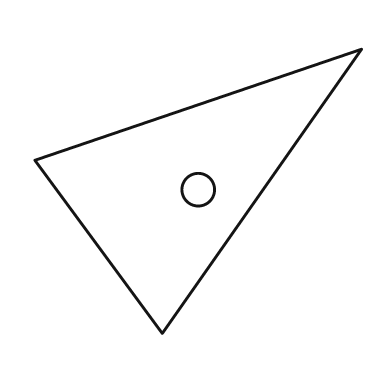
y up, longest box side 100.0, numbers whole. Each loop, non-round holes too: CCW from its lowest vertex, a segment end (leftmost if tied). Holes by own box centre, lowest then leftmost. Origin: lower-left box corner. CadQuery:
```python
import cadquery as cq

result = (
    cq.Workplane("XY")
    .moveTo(39.0, 0.0)
    .lineTo(100.0, 87.0)
    .lineTo(0.0, 53.0)
    .close()
    .moveTo(50.0, 44.0)
    .circle(5.0)
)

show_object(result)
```